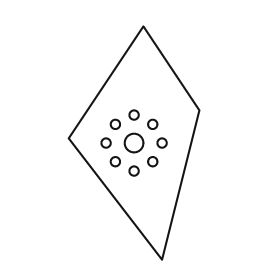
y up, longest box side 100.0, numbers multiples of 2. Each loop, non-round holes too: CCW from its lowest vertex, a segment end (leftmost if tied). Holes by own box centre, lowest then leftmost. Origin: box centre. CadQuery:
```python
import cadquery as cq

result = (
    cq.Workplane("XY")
    .moveTo(12.0, -50.0)
    .lineTo(28.0, 14.0)
    .lineTo(4.0, 50.0)
    .lineTo(-28.0, 2.0)
    .close()
    .moveTo(0.0, -12.0)
    .circle(2.0)
    .moveTo(-8.0, -8.0)
    .circle(2.0)
    .moveTo(8.0, -8.0)
    .circle(2.0)
    .moveTo(-12.0, 0.0)
    .circle(2.0)
    .moveTo(0.0, 0.0)
    .circle(4.0)
    .moveTo(12.0, 0.0)
    .circle(2.0)
    .moveTo(-8.0, 8.0)
    .circle(2.0)
    .moveTo(8.0, 8.0)
    .circle(2.0)
    .moveTo(0.0, 12.0)
    .circle(2.0)
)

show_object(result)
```